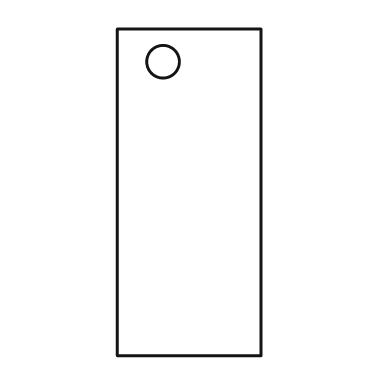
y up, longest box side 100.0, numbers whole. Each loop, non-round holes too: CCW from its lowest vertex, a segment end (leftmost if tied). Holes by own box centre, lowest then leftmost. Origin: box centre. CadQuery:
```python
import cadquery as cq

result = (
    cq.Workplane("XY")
    .moveTo(-22.0, -50.0)
    .lineTo(22.0, -50.0)
    .lineTo(22.0, 50.0)
    .lineTo(-22.0, 50.0)
    .close()
    .moveTo(-8.0, 40.0)
    .circle(5.0)
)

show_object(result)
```